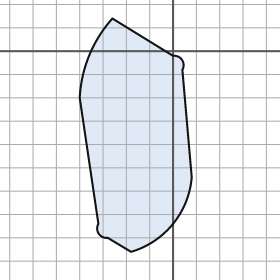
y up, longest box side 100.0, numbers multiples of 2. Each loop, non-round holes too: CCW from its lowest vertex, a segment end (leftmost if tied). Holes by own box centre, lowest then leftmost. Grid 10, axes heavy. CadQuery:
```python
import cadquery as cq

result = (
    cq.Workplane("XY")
    .moveTo(-18.0, -86.0)
    .threePointArc((0.0, -74.0), (8.0, -54.0))
    .lineTo(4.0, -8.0)
    .threePointArc((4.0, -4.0), (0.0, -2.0))
    .lineTo(-26.0, 14.0)
    .threePointArc((-36.0, -2.0), (-40.0, -20.0))
    .lineTo(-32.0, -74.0)
    .threePointArc((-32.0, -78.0), (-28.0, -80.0))
    .close()
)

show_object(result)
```